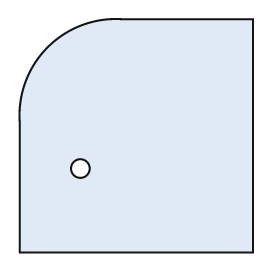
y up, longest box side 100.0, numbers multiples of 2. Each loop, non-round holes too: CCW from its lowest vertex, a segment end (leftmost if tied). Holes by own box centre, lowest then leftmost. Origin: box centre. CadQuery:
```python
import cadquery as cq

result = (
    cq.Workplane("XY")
    .moveTo(-50.0, -50.0)
    .lineTo(50.0, -50.0)
    .lineTo(50.0, 50.0)
    .lineTo(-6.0, 50.0)
    .threePointArc((-38.0, 38.0), (-50.0, 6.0))
    .close()
    .moveTo(-24.0, -14.0)
    .circle(4.0)
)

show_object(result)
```